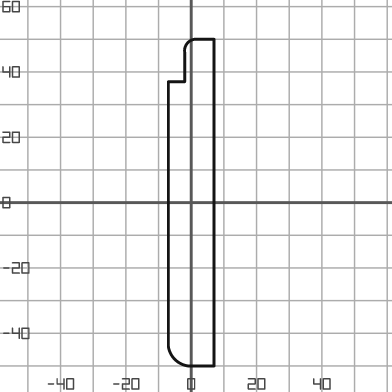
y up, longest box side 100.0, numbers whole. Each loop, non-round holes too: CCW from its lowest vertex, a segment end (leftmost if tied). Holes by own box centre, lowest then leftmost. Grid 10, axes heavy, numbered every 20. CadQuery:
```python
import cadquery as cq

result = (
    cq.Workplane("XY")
    .moveTo(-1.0, -50.0)
    .lineTo(7.0, -50.0)
    .lineTo(7.0, 50.0)
    .lineTo(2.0, 50.0)
    .threePointArc((-1.0, 49.0), (-2.0, 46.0))
    .lineTo(-2.0, 37.0)
    .lineTo(-7.0, 37.0)
    .lineTo(-7.0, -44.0)
    .threePointArc((-5.0, -48.0), (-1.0, -50.0))
    .close()
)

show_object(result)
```